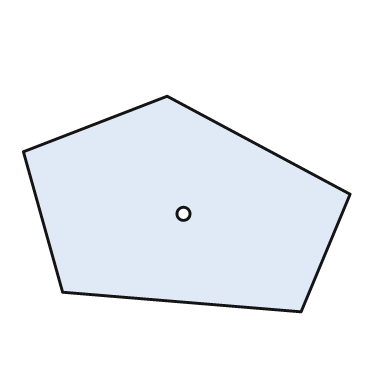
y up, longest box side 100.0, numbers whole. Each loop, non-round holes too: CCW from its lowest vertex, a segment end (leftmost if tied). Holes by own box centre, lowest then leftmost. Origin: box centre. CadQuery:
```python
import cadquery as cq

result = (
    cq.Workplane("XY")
    .moveTo(35.0, -33.0)
    .lineTo(50.0, 3.0)
    .lineTo(-6.0, 33.0)
    .lineTo(-50.0, 16.0)
    .lineTo(-38.0, -27.0)
    .close()
    .moveTo(-1.0, -3.0)
    .circle(2.0)
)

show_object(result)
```